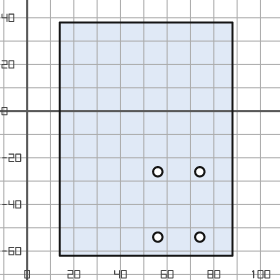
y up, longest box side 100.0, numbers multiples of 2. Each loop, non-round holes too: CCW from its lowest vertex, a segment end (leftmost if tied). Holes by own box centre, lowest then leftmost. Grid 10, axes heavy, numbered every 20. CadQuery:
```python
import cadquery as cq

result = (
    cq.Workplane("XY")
    .moveTo(14.0, -62.0)
    .lineTo(88.0, -62.0)
    .lineTo(88.0, 38.0)
    .lineTo(14.0, 38.0)
    .close()
    .moveTo(56.0, -54.0)
    .circle(2.0)
    .moveTo(74.0, -54.0)
    .circle(2.0)
    .moveTo(56.0, -26.0)
    .circle(2.0)
    .moveTo(74.0, -26.0)
    .circle(2.0)
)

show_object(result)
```